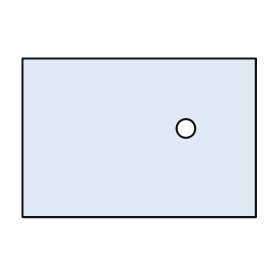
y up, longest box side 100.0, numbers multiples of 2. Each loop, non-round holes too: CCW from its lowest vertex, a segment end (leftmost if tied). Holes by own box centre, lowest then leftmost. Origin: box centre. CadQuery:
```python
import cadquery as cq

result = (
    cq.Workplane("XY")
    .moveTo(-50.0, -34.0)
    .lineTo(50.0, -34.0)
    .lineTo(50.0, 34.0)
    .lineTo(-50.0, 34.0)
    .close()
    .moveTo(20.0, 4.0)
    .circle(4.0)
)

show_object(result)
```